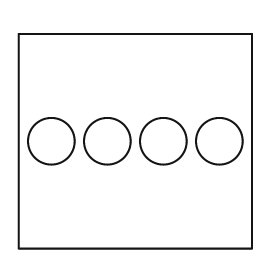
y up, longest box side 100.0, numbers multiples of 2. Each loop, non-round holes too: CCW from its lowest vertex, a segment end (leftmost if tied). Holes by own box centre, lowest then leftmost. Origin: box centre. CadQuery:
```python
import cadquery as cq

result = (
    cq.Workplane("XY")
    .moveTo(-50.0, -46.0)
    .lineTo(50.0, -46.0)
    .lineTo(50.0, 46.0)
    .lineTo(-50.0, 46.0)
    .close()
    .moveTo(-36.0, 0.0)
    .circle(10.0)
    .moveTo(-12.0, 0.0)
    .circle(10.0)
    .moveTo(12.0, 0.0)
    .circle(10.0)
    .moveTo(36.0, 0.0)
    .circle(10.0)
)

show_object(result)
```